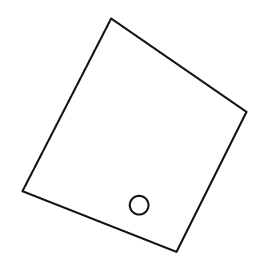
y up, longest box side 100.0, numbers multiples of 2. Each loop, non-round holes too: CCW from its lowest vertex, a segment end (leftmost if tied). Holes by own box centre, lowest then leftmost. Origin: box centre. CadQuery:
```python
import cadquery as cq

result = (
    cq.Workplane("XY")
    .moveTo(18.0, -50.0)
    .lineTo(48.0, 10.0)
    .lineTo(-10.0, 50.0)
    .lineTo(-48.0, -24.0)
    .close()
    .moveTo(2.0, -30.0)
    .circle(4.0)
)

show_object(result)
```